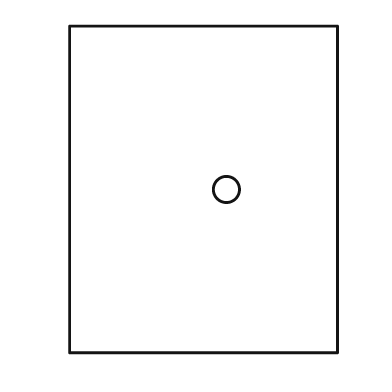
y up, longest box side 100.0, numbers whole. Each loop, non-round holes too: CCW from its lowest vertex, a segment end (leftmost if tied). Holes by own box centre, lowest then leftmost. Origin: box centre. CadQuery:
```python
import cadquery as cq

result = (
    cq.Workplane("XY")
    .moveTo(-41.0, -50.0)
    .lineTo(41.0, -50.0)
    .lineTo(41.0, 50.0)
    .lineTo(-41.0, 50.0)
    .close()
    .moveTo(7.0, 0.0)
    .circle(4.0)
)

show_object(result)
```